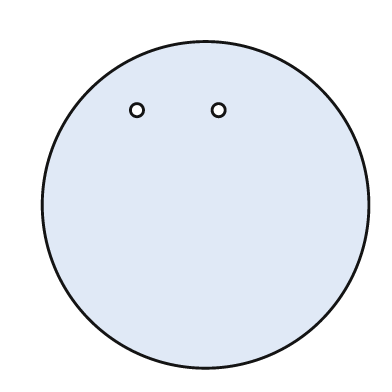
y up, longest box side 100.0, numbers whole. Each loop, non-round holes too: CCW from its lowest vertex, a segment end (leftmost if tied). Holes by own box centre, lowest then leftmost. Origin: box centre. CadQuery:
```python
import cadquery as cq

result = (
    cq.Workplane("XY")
    .moveTo(0.0, 0.0)
    .circle(50.0)
    .moveTo(-21.0, 29.0)
    .circle(2.0)
    .moveTo(4.0, 29.0)
    .circle(2.0)
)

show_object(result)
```